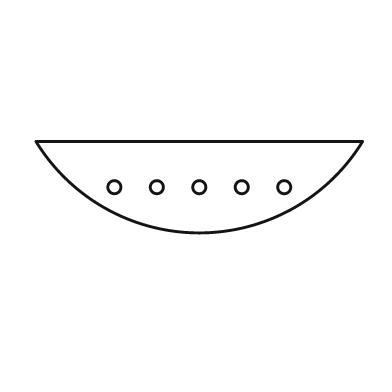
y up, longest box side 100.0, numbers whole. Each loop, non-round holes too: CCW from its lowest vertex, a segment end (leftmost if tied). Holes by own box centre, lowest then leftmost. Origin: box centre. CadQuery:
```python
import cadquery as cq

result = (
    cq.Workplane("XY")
    .moveTo(-50.0, 14.0)
    .threePointArc((0.0, -14.0), (50.0, 14.0))
    .close()
    .moveTo(-26.0, 0.0)
    .circle(2.0)
    .moveTo(-13.0, 0.0)
    .circle(2.0)
    .moveTo(0.0, 0.0)
    .circle(2.0)
    .moveTo(13.0, 0.0)
    .circle(2.0)
    .moveTo(26.0, 0.0)
    .circle(2.0)
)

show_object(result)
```